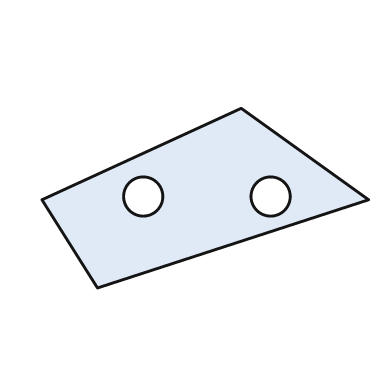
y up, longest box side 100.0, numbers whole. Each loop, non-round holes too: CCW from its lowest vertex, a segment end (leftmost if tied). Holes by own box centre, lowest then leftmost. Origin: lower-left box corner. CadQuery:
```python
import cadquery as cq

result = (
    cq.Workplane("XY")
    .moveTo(17.0, 0.0)
    .lineTo(100.0, 27.0)
    .lineTo(61.0, 55.0)
    .lineTo(0.0, 27.0)
    .close()
    .moveTo(31.0, 28.0)
    .circle(6.0)
    .moveTo(70.0, 28.0)
    .circle(6.0)
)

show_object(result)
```